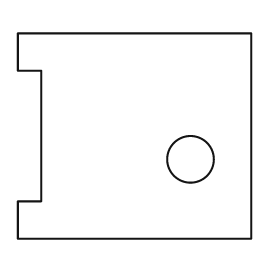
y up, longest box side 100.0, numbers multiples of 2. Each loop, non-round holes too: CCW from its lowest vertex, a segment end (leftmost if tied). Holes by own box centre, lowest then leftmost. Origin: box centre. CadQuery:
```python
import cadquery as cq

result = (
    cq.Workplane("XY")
    .moveTo(-50.0, -44.0)
    .lineTo(50.0, -44.0)
    .lineTo(50.0, 44.0)
    .lineTo(-50.0, 44.0)
    .lineTo(-50.0, 28.0)
    .lineTo(-40.0, 28.0)
    .lineTo(-40.0, -28.0)
    .lineTo(-50.0, -28.0)
    .close()
    .moveTo(24.0, -10.0)
    .circle(10.0)
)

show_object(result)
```